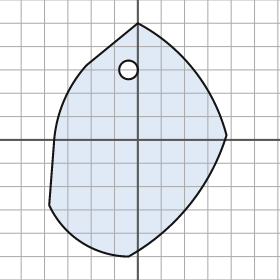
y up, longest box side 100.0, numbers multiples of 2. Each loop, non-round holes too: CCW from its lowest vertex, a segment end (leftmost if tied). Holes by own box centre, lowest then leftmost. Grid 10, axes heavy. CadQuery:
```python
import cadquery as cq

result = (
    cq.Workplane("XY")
    .moveTo(-4.0, -50.0)
    .threePointArc((22.0, -28.0), (38.0, 2.0))
    .threePointArc((24.0, 30.0), (0.0, 50.0))
    .lineTo(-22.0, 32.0)
    .threePointArc((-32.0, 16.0), (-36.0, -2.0))
    .lineTo(-38.0, -28.0)
    .threePointArc((-24.0, -44.0), (-4.0, -50.0))
    .close()
    .moveTo(-4.0, 30.0)
    .circle(4.0)
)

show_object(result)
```